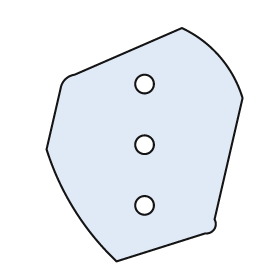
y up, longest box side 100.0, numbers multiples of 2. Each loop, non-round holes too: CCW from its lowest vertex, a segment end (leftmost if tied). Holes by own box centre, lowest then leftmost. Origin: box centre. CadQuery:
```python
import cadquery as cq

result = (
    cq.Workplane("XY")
    .moveTo(-12.0, -50.0)
    .lineTo(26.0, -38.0)
    .threePointArc((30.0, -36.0), (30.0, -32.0))
    .lineTo(42.0, 20.0)
    .threePointArc((32.0, 38.0), (16.0, 50.0))
    .lineTo(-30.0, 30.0)
    .threePointArc((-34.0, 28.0), (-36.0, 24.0))
    .lineTo(-42.0, -2.0)
    .threePointArc((-30.0, -28.0), (-12.0, -50.0))
    .close()
    .moveTo(0.0, -26.0)
    .circle(4.0)
    .moveTo(0.0, 0.0)
    .circle(4.0)
    .moveTo(0.0, 26.0)
    .circle(4.0)
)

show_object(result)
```